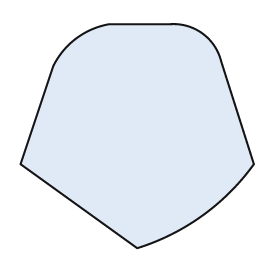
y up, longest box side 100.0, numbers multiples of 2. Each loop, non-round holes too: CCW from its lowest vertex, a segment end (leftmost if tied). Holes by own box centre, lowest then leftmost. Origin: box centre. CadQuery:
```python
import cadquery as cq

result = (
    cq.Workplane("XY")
    .moveTo(0.0, -48.0)
    .threePointArc((28.0, -34.0), (50.0, -12.0))
    .lineTo(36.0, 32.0)
    .threePointArc((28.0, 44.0), (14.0, 48.0))
    .lineTo(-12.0, 48.0)
    .threePointArc((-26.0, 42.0), (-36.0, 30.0))
    .lineTo(-50.0, -12.0)
    .close()
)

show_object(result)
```